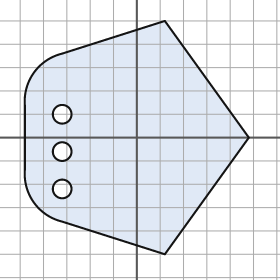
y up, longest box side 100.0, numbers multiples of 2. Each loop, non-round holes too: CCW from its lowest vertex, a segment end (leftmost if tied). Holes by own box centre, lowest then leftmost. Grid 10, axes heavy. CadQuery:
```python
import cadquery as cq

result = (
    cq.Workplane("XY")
    .moveTo(12.0, -50.0)
    .lineTo(48.0, 0.0)
    .lineTo(12.0, 50.0)
    .lineTo(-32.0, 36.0)
    .threePointArc((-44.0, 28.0), (-48.0, 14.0))
    .lineTo(-48.0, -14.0)
    .threePointArc((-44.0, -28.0), (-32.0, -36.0))
    .close()
    .moveTo(-32.0, -22.0)
    .circle(4.0)
    .moveTo(-32.0, -6.0)
    .circle(4.0)
    .moveTo(-32.0, 10.0)
    .circle(4.0)
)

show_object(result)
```